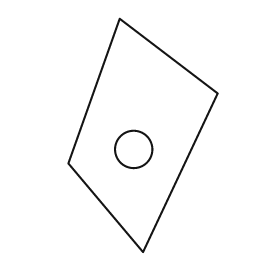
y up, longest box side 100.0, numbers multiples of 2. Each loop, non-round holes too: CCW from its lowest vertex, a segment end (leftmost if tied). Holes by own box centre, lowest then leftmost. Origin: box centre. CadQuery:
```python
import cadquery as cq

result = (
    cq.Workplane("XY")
    .moveTo(0.0, -50.0)
    .lineTo(32.0, 18.0)
    .lineTo(-10.0, 50.0)
    .lineTo(-32.0, -12.0)
    .close()
    .moveTo(-4.0, -6.0)
    .circle(8.0)
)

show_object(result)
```